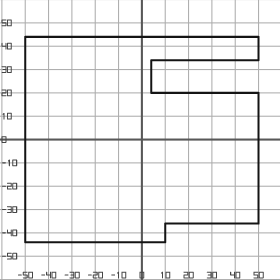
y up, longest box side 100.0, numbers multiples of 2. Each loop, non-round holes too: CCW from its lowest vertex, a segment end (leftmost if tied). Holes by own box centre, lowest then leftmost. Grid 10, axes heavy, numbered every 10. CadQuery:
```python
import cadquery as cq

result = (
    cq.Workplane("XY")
    .moveTo(-50.0, -44.0)
    .lineTo(10.0, -44.0)
    .lineTo(10.0, -36.0)
    .lineTo(50.0, -36.0)
    .lineTo(50.0, 20.0)
    .lineTo(4.0, 20.0)
    .lineTo(4.0, 34.0)
    .lineTo(50.0, 34.0)
    .lineTo(50.0, 44.0)
    .lineTo(-50.0, 44.0)
    .close()
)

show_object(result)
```